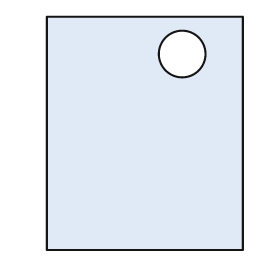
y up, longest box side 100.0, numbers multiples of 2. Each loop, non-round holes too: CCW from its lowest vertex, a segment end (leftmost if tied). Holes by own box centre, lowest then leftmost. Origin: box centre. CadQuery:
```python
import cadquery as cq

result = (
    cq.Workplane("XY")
    .moveTo(-42.0, -50.0)
    .lineTo(42.0, -50.0)
    .lineTo(42.0, 50.0)
    .lineTo(-42.0, 50.0)
    .close()
    .moveTo(16.0, 34.0)
    .circle(10.0)
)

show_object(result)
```